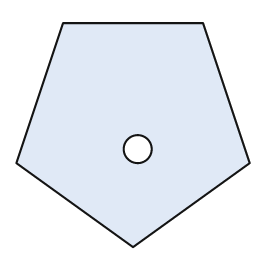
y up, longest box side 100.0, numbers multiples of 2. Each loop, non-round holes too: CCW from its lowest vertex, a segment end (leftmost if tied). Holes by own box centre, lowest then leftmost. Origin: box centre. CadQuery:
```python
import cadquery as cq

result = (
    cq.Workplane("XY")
    .moveTo(0.0, -48.0)
    .lineTo(50.0, -12.0)
    .lineTo(30.0, 48.0)
    .lineTo(-30.0, 48.0)
    .lineTo(-50.0, -12.0)
    .close()
    .moveTo(2.0, -6.0)
    .circle(6.0)
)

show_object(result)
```